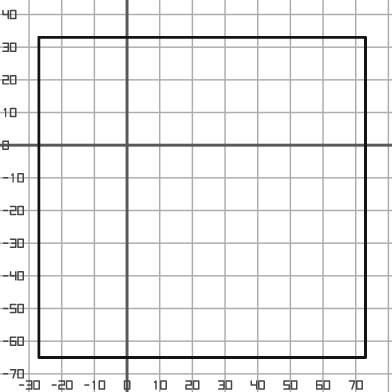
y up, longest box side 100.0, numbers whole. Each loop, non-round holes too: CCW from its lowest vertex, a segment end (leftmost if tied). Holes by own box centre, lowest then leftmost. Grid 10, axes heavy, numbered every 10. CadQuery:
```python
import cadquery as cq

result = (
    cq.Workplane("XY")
    .moveTo(-27.0, -65.0)
    .lineTo(73.0, -65.0)
    .lineTo(73.0, 33.0)
    .lineTo(-27.0, 33.0)
    .close()
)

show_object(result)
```